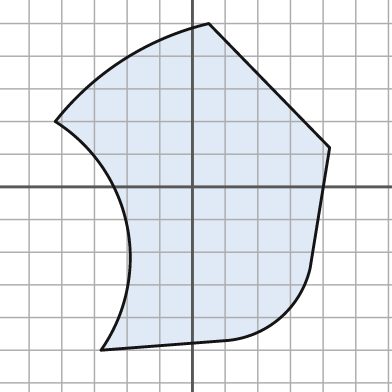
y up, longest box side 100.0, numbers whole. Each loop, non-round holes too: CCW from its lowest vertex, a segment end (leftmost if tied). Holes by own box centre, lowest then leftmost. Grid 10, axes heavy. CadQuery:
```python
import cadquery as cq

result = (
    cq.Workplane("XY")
    .moveTo(-28.0, -50.0)
    .lineTo(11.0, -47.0)
    .threePointArc((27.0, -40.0), (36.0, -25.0))
    .lineTo(42.0, 12.0)
    .lineTo(5.0, 50.0)
    .threePointArc((-21.0, 39.0), (-42.0, 20.0))
    .threePointArc((-20.0, -12.0), (-28.0, -50.0))
    .close()
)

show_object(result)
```